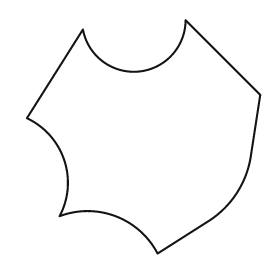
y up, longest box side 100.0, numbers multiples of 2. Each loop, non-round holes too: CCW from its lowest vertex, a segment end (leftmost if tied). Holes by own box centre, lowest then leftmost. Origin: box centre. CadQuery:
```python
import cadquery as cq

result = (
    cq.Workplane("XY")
    .moveTo(6.0, -50.0)
    .lineTo(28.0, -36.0)
    .threePointArc((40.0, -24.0), (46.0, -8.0))
    .lineTo(50.0, 18.0)
    .lineTo(18.0, 50.0)
    .threePointArc((-2.0, 28.0), (-26.0, 46.0))
    .lineTo(-50.0, 8.0)
    .threePointArc((-34.0, -10.0), (-36.0, -34.0))
    .threePointArc((-12.0, -34.0), (6.0, -50.0))
    .close()
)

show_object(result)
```